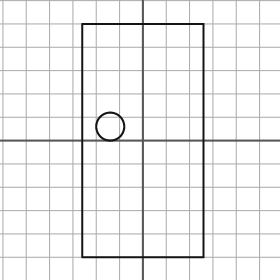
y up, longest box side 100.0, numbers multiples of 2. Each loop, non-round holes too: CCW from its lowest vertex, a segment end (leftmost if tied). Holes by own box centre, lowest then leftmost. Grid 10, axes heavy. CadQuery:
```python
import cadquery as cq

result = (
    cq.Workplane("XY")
    .moveTo(-26.0, -50.0)
    .lineTo(26.0, -50.0)
    .lineTo(26.0, 50.0)
    .lineTo(-26.0, 50.0)
    .close()
    .moveTo(-14.0, 6.0)
    .circle(6.0)
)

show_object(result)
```